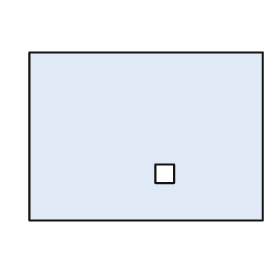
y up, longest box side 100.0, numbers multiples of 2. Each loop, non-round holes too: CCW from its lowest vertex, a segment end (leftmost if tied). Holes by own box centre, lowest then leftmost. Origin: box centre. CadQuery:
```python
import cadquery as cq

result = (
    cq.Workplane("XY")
    .moveTo(-50.0, -36.0)
    .lineTo(50.0, -36.0)
    .lineTo(50.0, 36.0)
    .lineTo(-50.0, 36.0)
    .close()
    .moveTo(4.0, -20.0)
    .lineTo(12.0, -20.0)
    .lineTo(12.0, -12.0)
    .lineTo(4.0, -12.0)
    .close()
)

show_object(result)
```